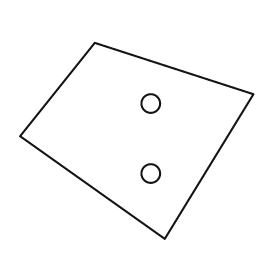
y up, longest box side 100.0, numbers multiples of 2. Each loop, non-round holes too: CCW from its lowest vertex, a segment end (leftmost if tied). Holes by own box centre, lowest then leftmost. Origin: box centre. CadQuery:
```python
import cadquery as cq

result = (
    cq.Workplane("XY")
    .moveTo(12.0, -42.0)
    .lineTo(50.0, 20.0)
    .lineTo(-18.0, 42.0)
    .lineTo(-50.0, 2.0)
    .close()
    .moveTo(6.0, -14.0)
    .circle(4.0)
    .moveTo(6.0, 16.0)
    .circle(4.0)
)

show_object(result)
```